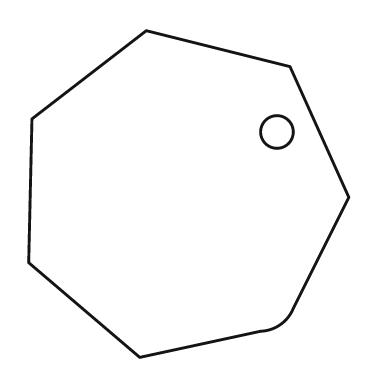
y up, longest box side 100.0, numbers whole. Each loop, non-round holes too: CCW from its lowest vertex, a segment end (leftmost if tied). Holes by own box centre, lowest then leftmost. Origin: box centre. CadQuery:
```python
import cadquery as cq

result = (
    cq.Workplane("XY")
    .moveTo(-15.0, -50.0)
    .lineTo(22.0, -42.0)
    .threePointArc((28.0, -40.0), (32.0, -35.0))
    .lineTo(49.0, -1.0)
    .lineTo(31.0, 39.0)
    .lineTo(-13.0, 50.0)
    .lineTo(-48.0, 23.0)
    .lineTo(-49.0, -21.0)
    .close()
    .moveTo(27.0, 19.0)
    .circle(5.0)
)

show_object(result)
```